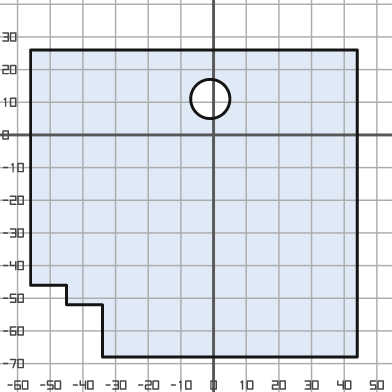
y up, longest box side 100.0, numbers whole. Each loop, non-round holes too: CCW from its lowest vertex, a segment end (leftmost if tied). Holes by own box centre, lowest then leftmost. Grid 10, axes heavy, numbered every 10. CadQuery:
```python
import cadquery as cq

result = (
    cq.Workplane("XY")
    .moveTo(-34.0, -68.0)
    .lineTo(44.0, -68.0)
    .lineTo(44.0, 26.0)
    .lineTo(-56.0, 26.0)
    .lineTo(-56.0, -46.0)
    .lineTo(-45.0, -46.0)
    .lineTo(-45.0, -52.0)
    .lineTo(-34.0, -52.0)
    .close()
    .moveTo(-1.0, 11.0)
    .circle(6.0)
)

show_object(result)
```